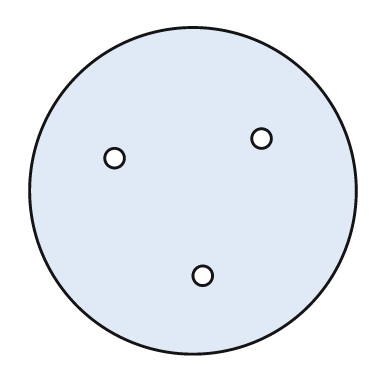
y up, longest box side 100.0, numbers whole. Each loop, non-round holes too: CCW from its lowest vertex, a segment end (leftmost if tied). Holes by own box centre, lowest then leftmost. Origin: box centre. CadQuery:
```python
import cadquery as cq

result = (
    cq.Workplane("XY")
    .moveTo(0.0, 0.0)
    .circle(50.0)
    .moveTo(3.0, -26.0)
    .circle(3.0)
    .moveTo(-24.0, 10.0)
    .circle(3.0)
    .moveTo(21.0, 16.0)
    .circle(3.0)
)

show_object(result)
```